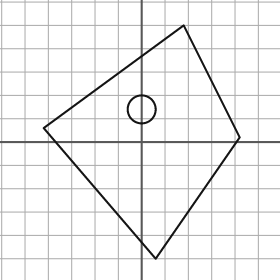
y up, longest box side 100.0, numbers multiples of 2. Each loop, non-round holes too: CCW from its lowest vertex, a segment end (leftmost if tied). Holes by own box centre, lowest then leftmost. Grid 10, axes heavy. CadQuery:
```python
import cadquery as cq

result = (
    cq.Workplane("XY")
    .moveTo(6.0, -50.0)
    .lineTo(42.0, 2.0)
    .lineTo(18.0, 50.0)
    .lineTo(-42.0, 6.0)
    .close()
    .moveTo(0.0, 14.0)
    .circle(6.0)
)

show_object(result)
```